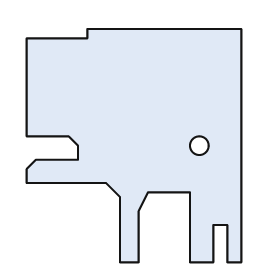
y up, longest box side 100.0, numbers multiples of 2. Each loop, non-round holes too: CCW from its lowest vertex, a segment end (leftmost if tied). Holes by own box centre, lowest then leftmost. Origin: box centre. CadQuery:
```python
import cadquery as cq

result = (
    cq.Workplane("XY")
    .moveTo(-6.0, -50.0)
    .lineTo(2.0, -50.0)
    .lineTo(2.0, -28.0)
    .lineTo(6.0, -20.0)
    .lineTo(24.0, -20.0)
    .lineTo(24.0, -50.0)
    .lineTo(34.0, -50.0)
    .lineTo(34.0, -34.0)
    .lineTo(40.0, -34.0)
    .lineTo(40.0, -50.0)
    .lineTo(46.0, -50.0)
    .lineTo(46.0, 50.0)
    .lineTo(-20.0, 50.0)
    .lineTo(-20.0, 46.0)
    .lineTo(-46.0, 46.0)
    .lineTo(-46.0, 4.0)
    .lineTo(-28.0, 4.0)
    .lineTo(-24.0, 0.0)
    .lineTo(-24.0, -6.0)
    .lineTo(-42.0, -6.0)
    .lineTo(-46.0, -10.0)
    .lineTo(-46.0, -16.0)
    .lineTo(-12.0, -16.0)
    .lineTo(-6.0, -22.0)
    .close()
    .moveTo(28.0, 0.0)
    .circle(4.0)
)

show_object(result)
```